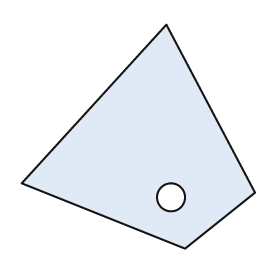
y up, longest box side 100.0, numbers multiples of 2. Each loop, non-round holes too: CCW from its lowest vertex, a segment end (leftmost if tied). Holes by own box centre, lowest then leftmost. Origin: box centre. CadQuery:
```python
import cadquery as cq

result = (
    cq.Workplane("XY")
    .moveTo(20.0, -48.0)
    .lineTo(50.0, -24.0)
    .lineTo(12.0, 48.0)
    .lineTo(-50.0, -20.0)
    .close()
    .moveTo(14.0, -26.0)
    .circle(6.0)
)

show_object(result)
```